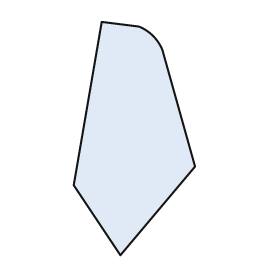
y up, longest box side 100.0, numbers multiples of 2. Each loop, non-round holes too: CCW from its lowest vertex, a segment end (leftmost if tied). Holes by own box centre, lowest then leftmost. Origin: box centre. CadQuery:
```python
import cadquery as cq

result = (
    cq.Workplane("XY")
    .moveTo(-6.0, -50.0)
    .lineTo(26.0, -12.0)
    .lineTo(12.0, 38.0)
    .threePointArc((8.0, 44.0), (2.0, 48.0))
    .lineTo(-14.0, 50.0)
    .lineTo(-26.0, -20.0)
    .close()
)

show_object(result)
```